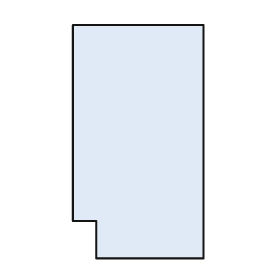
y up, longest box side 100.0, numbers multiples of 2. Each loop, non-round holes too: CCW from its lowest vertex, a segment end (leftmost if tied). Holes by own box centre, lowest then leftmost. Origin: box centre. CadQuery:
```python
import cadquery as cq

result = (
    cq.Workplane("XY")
    .moveTo(-18.0, -50.0)
    .lineTo(28.0, -50.0)
    .lineTo(28.0, 50.0)
    .lineTo(-28.0, 50.0)
    .lineTo(-28.0, -34.0)
    .lineTo(-18.0, -34.0)
    .close()
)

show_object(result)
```